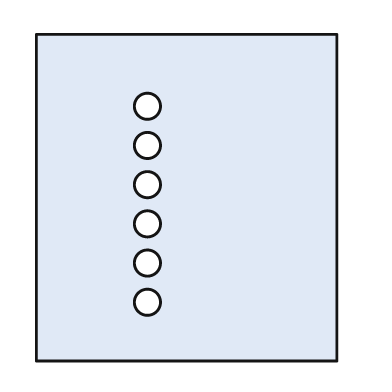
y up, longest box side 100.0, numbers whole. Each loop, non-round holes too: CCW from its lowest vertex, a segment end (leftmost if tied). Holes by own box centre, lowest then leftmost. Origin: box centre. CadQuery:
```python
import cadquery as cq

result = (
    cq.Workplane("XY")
    .moveTo(-46.0, -50.0)
    .lineTo(46.0, -50.0)
    .lineTo(46.0, 50.0)
    .lineTo(-46.0, 50.0)
    .close()
    .moveTo(-12.0, -32.0)
    .circle(4.0)
    .moveTo(-12.0, -20.0)
    .circle(4.0)
    .moveTo(-12.0, -8.0)
    .circle(4.0)
    .moveTo(-12.0, 4.0)
    .circle(4.0)
    .moveTo(-12.0, 16.0)
    .circle(4.0)
    .moveTo(-12.0, 28.0)
    .circle(4.0)
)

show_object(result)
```